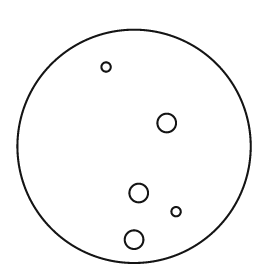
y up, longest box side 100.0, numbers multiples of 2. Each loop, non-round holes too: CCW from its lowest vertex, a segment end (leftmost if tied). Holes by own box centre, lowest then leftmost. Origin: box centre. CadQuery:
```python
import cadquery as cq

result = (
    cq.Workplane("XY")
    .moveTo(0.0, 0.0)
    .circle(50.0)
    .moveTo(0.0, -40.0)
    .circle(4.0)
    .moveTo(18.0, -28.0)
    .circle(2.0)
    .moveTo(2.0, -20.0)
    .circle(4.0)
    .moveTo(14.0, 10.0)
    .circle(4.0)
    .moveTo(-12.0, 34.0)
    .circle(2.0)
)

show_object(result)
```